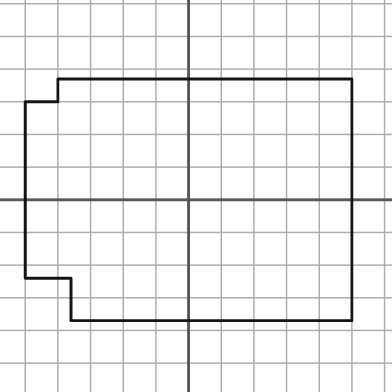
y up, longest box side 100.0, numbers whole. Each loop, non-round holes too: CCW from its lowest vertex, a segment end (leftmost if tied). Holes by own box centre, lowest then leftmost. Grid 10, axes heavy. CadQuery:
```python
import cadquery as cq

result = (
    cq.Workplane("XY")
    .moveTo(-36.0, -37.0)
    .lineTo(50.0, -37.0)
    .lineTo(50.0, 37.0)
    .lineTo(-40.0, 37.0)
    .lineTo(-40.0, 30.0)
    .lineTo(-50.0, 30.0)
    .lineTo(-50.0, -24.0)
    .lineTo(-36.0, -24.0)
    .close()
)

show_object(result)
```